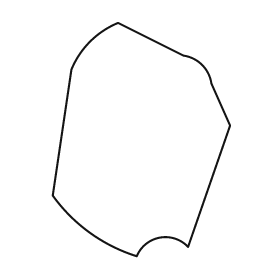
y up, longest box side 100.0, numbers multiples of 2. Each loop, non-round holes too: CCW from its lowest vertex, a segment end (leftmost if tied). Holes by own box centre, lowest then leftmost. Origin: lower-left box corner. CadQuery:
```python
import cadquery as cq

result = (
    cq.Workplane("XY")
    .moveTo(36.0, 0.0)
    .threePointArc((46.0, 8.0), (58.0, 4.0))
    .lineTo(76.0, 56.0)
    .lineTo(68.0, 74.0)
    .threePointArc((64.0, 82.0), (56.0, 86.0))
    .lineTo(28.0, 100.0)
    .threePointArc((16.0, 92.0), (8.0, 80.0))
    .lineTo(0.0, 26.0)
    .threePointArc((16.0, 10.0), (36.0, 0.0))
    .close()
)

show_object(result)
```